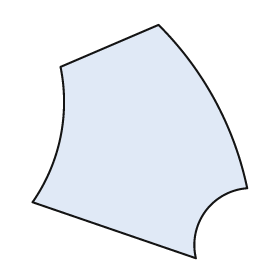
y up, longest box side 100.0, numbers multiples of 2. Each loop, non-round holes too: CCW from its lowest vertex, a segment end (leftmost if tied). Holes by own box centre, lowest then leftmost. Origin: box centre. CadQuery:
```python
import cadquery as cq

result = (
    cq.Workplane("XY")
    .moveTo(24.0, -50.0)
    .threePointArc((28.0, -30.0), (46.0, -20.0))
    .threePointArc((32.0, 18.0), (8.0, 50.0))
    .lineTo(-34.0, 32.0)
    .threePointArc((-34.0, 2.0), (-46.0, -26.0))
    .close()
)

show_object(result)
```